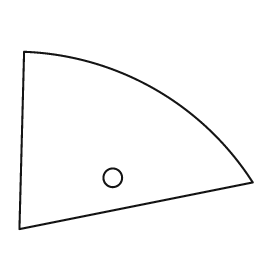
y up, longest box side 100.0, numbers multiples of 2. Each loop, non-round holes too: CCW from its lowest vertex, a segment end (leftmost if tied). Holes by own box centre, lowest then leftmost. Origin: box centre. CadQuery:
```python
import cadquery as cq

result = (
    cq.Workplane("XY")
    .moveTo(-50.0, -38.0)
    .lineTo(50.0, -18.0)
    .threePointArc((8.0, 22.0), (-48.0, 38.0))
    .close()
    .moveTo(-10.0, -16.0)
    .circle(4.0)
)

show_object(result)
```